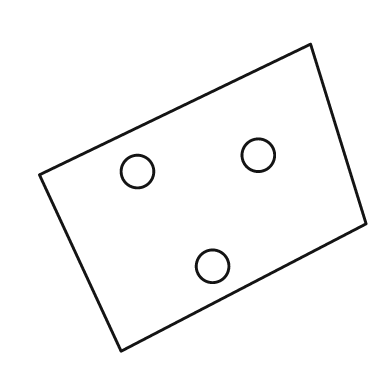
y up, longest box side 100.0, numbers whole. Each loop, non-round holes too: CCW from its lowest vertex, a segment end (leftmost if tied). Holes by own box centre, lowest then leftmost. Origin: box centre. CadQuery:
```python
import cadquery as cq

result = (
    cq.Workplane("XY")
    .moveTo(-25.0, -47.0)
    .lineTo(50.0, -8.0)
    .lineTo(33.0, 47.0)
    .lineTo(-50.0, 7.0)
    .close()
    .moveTo(3.0, -21.0)
    .circle(5.0)
    .moveTo(-20.0, 8.0)
    .circle(5.0)
    .moveTo(17.0, 13.0)
    .circle(5.0)
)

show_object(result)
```